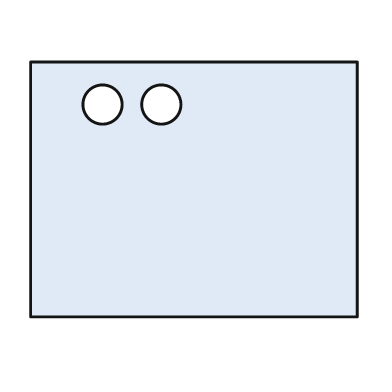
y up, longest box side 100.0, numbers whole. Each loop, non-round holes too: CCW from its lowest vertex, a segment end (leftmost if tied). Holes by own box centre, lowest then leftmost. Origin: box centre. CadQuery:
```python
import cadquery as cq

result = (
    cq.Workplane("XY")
    .moveTo(-50.0, -39.0)
    .lineTo(50.0, -39.0)
    .lineTo(50.0, 39.0)
    .lineTo(-50.0, 39.0)
    .close()
    .moveTo(-28.0, 26.0)
    .circle(6.0)
    .moveTo(-10.0, 26.0)
    .circle(6.0)
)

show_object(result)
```